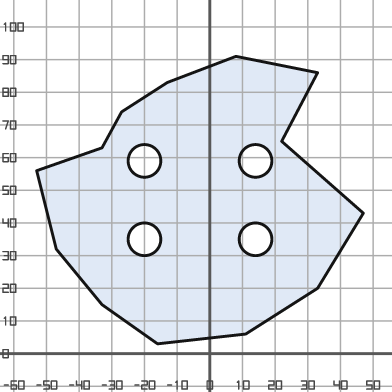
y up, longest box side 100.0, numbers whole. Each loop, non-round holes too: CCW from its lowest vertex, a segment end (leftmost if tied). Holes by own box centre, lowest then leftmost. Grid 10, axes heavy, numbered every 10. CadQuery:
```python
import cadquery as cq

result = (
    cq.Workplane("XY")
    .moveTo(-16.0, 3.0)
    .lineTo(11.0, 6.0)
    .lineTo(33.0, 20.0)
    .lineTo(47.0, 43.0)
    .lineTo(22.0, 65.0)
    .lineTo(33.0, 86.0)
    .lineTo(8.0, 91.0)
    .lineTo(-13.0, 83.0)
    .lineTo(-27.0, 74.0)
    .lineTo(-33.0, 63.0)
    .lineTo(-53.0, 56.0)
    .lineTo(-47.0, 32.0)
    .lineTo(-33.0, 15.0)
    .close()
    .moveTo(-20.0, 35.0)
    .circle(5.0)
    .moveTo(14.0, 35.0)
    .circle(5.0)
    .moveTo(-20.0, 59.0)
    .circle(5.0)
    .moveTo(14.0, 59.0)
    .circle(5.0)
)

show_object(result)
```